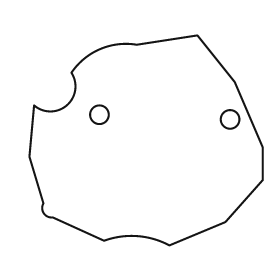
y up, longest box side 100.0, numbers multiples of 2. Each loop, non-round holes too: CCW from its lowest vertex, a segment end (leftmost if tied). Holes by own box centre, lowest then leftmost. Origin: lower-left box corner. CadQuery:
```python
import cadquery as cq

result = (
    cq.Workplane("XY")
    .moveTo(60.0, 0.0)
    .lineTo(84.0, 10.0)
    .lineTo(100.0, 28.0)
    .lineTo(100.0, 42.0)
    .lineTo(88.0, 70.0)
    .lineTo(72.0, 90.0)
    .lineTo(46.0, 86.0)
    .threePointArc((30.0, 84.0), (18.0, 74.0))
    .threePointArc((16.0, 60.0), (2.0, 60.0))
    .lineTo(0.0, 38.0)
    .lineTo(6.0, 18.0)
    .threePointArc((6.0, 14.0), (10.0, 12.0))
    .lineTo(32.0, 2.0)
    .threePointArc((46.0, 4.0), (60.0, 0.0))
    .close()
    .moveTo(86.0, 54.0)
    .circle(4.0)
    .moveTo(30.0, 56.0)
    .circle(4.0)
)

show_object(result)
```